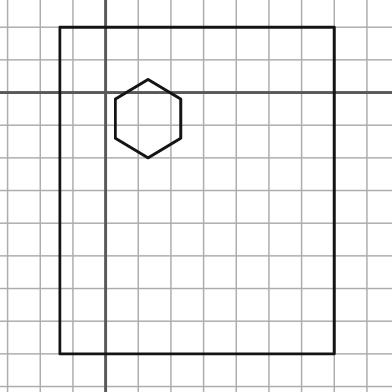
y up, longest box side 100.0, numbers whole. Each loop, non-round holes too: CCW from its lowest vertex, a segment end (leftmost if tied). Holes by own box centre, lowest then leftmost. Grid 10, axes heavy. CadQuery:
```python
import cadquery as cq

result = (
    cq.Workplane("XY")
    .moveTo(-14.0, -80.0)
    .lineTo(70.0, -80.0)
    .lineTo(70.0, 20.0)
    .lineTo(-14.0, 20.0)
    .close()
    .moveTo(13.0, -20.0)
    .lineTo(23.0, -14.0)
    .lineTo(23.0, -2.0)
    .lineTo(13.0, 4.0)
    .lineTo(3.0, -2.0)
    .lineTo(3.0, -14.0)
    .close()
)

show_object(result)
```